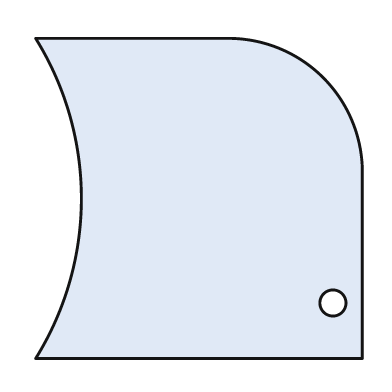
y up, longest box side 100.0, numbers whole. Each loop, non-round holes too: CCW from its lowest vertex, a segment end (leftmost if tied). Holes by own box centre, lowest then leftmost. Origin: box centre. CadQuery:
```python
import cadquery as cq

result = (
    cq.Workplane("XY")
    .moveTo(-50.0, -49.0)
    .lineTo(50.0, -49.0)
    .lineTo(50.0, 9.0)
    .threePointArc((38.0, 37.0), (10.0, 49.0))
    .lineTo(-50.0, 49.0)
    .threePointArc((-36.0, 0.0), (-50.0, -49.0))
    .close()
    .moveTo(41.0, -32.0)
    .circle(4.0)
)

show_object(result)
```